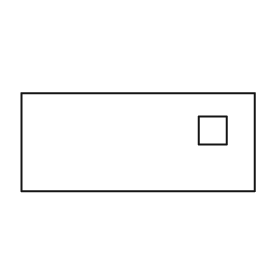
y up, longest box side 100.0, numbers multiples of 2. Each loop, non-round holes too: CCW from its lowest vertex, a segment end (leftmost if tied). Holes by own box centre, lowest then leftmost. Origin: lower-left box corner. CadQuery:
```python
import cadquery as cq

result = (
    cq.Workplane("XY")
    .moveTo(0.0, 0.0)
    .lineTo(100.0, 0.0)
    .lineTo(100.0, 42.0)
    .lineTo(0.0, 42.0)
    .close()
    .moveTo(76.0, 20.0)
    .lineTo(88.0, 20.0)
    .lineTo(88.0, 32.0)
    .lineTo(76.0, 32.0)
    .close()
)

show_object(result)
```